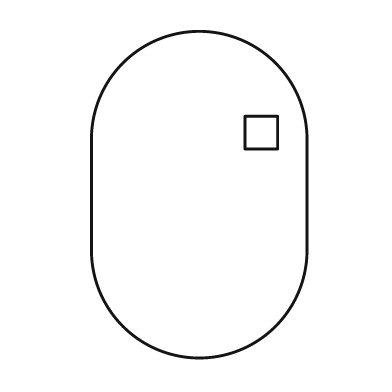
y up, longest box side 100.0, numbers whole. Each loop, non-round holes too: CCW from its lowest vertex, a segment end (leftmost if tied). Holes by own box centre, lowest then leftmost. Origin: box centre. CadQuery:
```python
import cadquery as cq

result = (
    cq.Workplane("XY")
    .moveTo(-33.0, -17.0)
    .threePointArc((0.0, -50.0), (33.0, -17.0))
    .lineTo(33.0, 17.0)
    .threePointArc((0.0, 50.0), (-33.0, 17.0))
    .close()
    .moveTo(14.0, 14.0)
    .lineTo(24.0, 14.0)
    .lineTo(24.0, 24.0)
    .lineTo(14.0, 24.0)
    .close()
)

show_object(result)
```